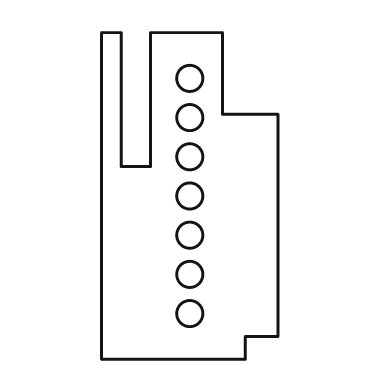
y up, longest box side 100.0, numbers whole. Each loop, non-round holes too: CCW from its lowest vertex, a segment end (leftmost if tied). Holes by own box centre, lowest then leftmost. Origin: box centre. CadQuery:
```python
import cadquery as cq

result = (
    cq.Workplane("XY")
    .moveTo(-27.0, -50.0)
    .lineTo(17.0, -50.0)
    .lineTo(17.0, -43.0)
    .lineTo(27.0, -43.0)
    .lineTo(27.0, 25.0)
    .lineTo(10.0, 25.0)
    .lineTo(10.0, 50.0)
    .lineTo(-12.0, 50.0)
    .lineTo(-12.0, 9.0)
    .lineTo(-21.0, 9.0)
    .lineTo(-21.0, 50.0)
    .lineTo(-27.0, 50.0)
    .close()
    .moveTo(0.0, -36.0)
    .circle(4.0)
    .moveTo(0.0, -24.0)
    .circle(4.0)
    .moveTo(0.0, -12.0)
    .circle(4.0)
    .moveTo(0.0, 0.0)
    .circle(4.0)
    .moveTo(0.0, 12.0)
    .circle(4.0)
    .moveTo(0.0, 24.0)
    .circle(4.0)
    .moveTo(0.0, 36.0)
    .circle(4.0)
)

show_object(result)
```